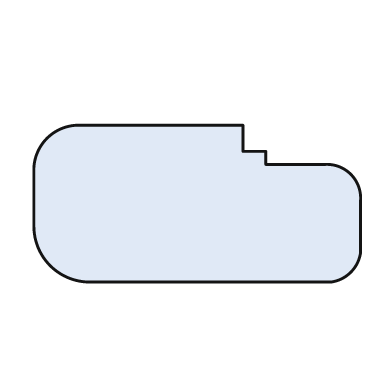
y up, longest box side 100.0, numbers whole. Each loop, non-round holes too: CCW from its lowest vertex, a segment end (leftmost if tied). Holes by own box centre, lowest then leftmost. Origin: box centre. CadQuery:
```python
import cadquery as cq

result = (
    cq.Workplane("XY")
    .moveTo(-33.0, -24.0)
    .lineTo(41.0, -24.0)
    .threePointArc((47.0, -21.0), (50.0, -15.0))
    .lineTo(50.0, 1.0)
    .threePointArc((47.0, 9.0), (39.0, 12.0))
    .lineTo(21.0, 12.0)
    .lineTo(21.0, 16.0)
    .lineTo(14.0, 16.0)
    .lineTo(14.0, 24.0)
    .lineTo(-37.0, 24.0)
    .threePointArc((-46.0, 20.0), (-50.0, 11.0))
    .lineTo(-50.0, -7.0)
    .threePointArc((-45.0, -19.0), (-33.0, -24.0))
    .close()
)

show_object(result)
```